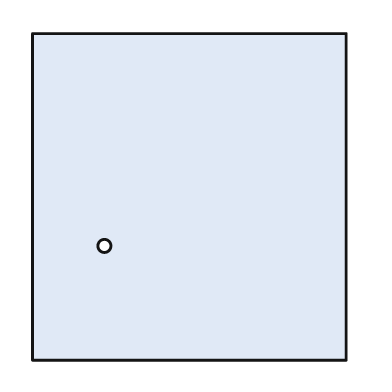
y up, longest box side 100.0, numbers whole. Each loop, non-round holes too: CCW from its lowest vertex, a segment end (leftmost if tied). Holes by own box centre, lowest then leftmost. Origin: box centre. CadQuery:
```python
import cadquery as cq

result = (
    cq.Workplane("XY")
    .moveTo(-48.0, -50.0)
    .lineTo(48.0, -50.0)
    .lineTo(48.0, 50.0)
    .lineTo(-48.0, 50.0)
    .close()
    .moveTo(-26.0, -15.0)
    .circle(2.0)
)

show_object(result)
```